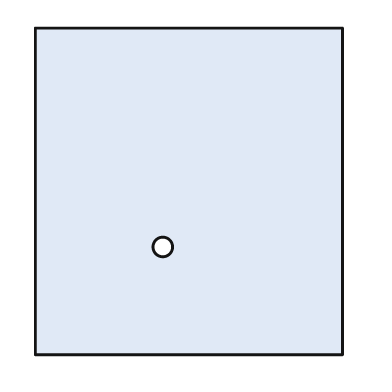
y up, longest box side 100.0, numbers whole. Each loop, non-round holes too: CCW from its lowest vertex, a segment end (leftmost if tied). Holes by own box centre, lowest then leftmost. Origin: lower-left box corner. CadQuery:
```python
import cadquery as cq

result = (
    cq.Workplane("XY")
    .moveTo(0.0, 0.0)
    .lineTo(94.0, 0.0)
    .lineTo(94.0, 100.0)
    .lineTo(0.0, 100.0)
    .close()
    .moveTo(39.0, 33.0)
    .circle(3.0)
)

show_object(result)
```